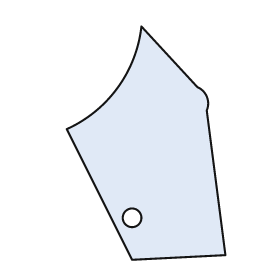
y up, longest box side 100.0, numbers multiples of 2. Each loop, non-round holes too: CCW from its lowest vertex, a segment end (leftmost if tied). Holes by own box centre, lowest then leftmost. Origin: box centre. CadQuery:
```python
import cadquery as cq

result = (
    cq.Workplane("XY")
    .moveTo(-6.0, -50.0)
    .lineTo(34.0, -48.0)
    .lineTo(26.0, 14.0)
    .threePointArc((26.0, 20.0), (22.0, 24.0))
    .lineTo(-2.0, 50.0)
    .threePointArc((-12.0, 24.0), (-34.0, 6.0))
    .close()
    .moveTo(-6.0, -32.0)
    .circle(4.0)
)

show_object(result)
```